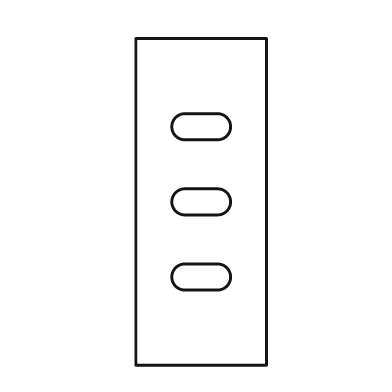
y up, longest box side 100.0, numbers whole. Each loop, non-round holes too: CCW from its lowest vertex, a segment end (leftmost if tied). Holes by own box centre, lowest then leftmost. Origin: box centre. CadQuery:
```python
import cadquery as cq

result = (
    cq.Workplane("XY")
    .moveTo(-20.0, -50.0)
    .lineTo(20.0, -50.0)
    .lineTo(20.0, 50.0)
    .lineTo(-20.0, 50.0)
    .close()
    .moveTo(-5.0, -27.0)
    .lineTo(5.0, -27.0)
    .threePointArc((9.0, -23.0), (5.0, -19.0))
    .lineTo(-5.0, -19.0)
    .threePointArc((-9.0, -23.0), (-5.0, -27.0))
    .close()
    .moveTo(-5.0, -4.0)
    .lineTo(5.0, -4.0)
    .threePointArc((9.0, 0.0), (5.0, 4.0))
    .lineTo(-5.0, 4.0)
    .threePointArc((-9.0, 0.0), (-5.0, -4.0))
    .close()
    .moveTo(-5.0, 19.0)
    .lineTo(5.0, 19.0)
    .threePointArc((9.0, 23.0), (5.0, 27.0))
    .lineTo(-5.0, 27.0)
    .threePointArc((-9.0, 23.0), (-5.0, 19.0))
    .close()
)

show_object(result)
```